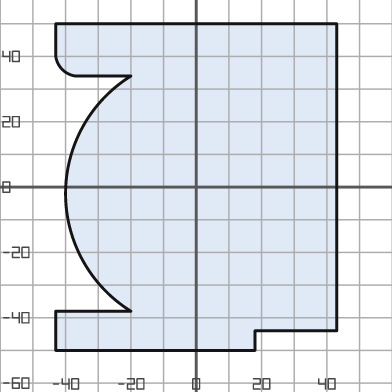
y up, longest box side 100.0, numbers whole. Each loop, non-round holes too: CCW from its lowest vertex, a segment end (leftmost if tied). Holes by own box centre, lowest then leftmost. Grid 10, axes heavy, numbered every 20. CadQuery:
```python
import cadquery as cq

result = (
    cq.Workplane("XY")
    .moveTo(-43.0, -50.0)
    .lineTo(18.0, -50.0)
    .lineTo(18.0, -44.0)
    .lineTo(43.0, -44.0)
    .lineTo(43.0, 50.0)
    .lineTo(-43.0, 50.0)
    .lineTo(-43.0, 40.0)
    .threePointArc((-41.0, 36.0), (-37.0, 34.0))
    .lineTo(-20.0, 34.0)
    .threePointArc((-40.0, -2.0), (-20.0, -38.0))
    .lineTo(-43.0, -38.0)
    .close()
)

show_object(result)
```